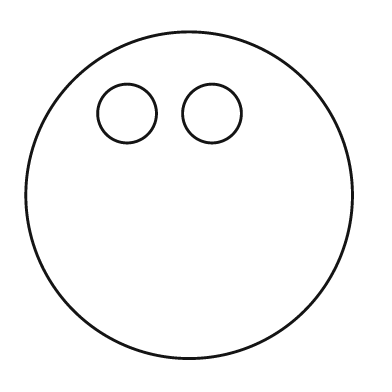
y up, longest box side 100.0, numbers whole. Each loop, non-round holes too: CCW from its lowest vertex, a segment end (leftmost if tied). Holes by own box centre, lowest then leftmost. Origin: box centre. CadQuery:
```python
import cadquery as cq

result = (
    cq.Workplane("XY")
    .moveTo(0.0, 0.0)
    .circle(50.0)
    .moveTo(-19.0, 25.0)
    .circle(9.0)
    .moveTo(7.0, 25.0)
    .circle(9.0)
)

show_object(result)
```